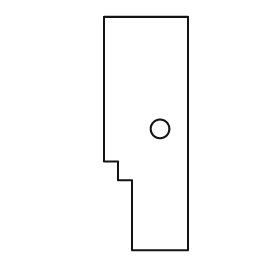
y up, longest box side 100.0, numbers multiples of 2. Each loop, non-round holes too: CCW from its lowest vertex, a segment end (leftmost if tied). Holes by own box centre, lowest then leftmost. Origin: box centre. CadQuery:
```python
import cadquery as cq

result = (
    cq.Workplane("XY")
    .moveTo(-6.0, -50.0)
    .lineTo(18.0, -50.0)
    .lineTo(18.0, 50.0)
    .lineTo(-18.0, 50.0)
    .lineTo(-18.0, -12.0)
    .lineTo(-12.0, -12.0)
    .lineTo(-12.0, -20.0)
    .lineTo(-6.0, -20.0)
    .close()
    .moveTo(6.0, 2.0)
    .circle(4.0)
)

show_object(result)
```